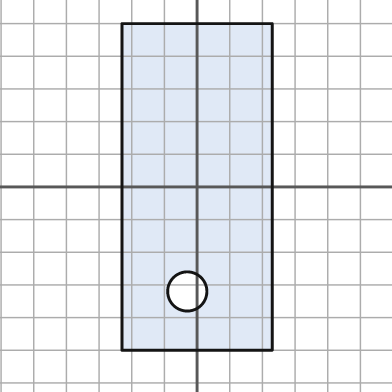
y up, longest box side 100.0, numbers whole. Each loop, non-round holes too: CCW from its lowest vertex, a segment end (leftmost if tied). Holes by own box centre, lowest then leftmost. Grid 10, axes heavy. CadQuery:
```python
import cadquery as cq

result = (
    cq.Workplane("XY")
    .moveTo(-23.0, -50.0)
    .lineTo(23.0, -50.0)
    .lineTo(23.0, 50.0)
    .lineTo(-23.0, 50.0)
    .close()
    .moveTo(-3.0, -32.0)
    .circle(6.0)
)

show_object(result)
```